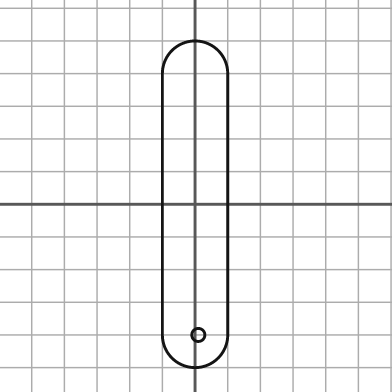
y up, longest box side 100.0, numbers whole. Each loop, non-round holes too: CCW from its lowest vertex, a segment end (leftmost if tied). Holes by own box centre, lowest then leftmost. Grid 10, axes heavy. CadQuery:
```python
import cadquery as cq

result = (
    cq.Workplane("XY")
    .moveTo(-10.0, -40.0)
    .threePointArc((0.0, -50.0), (10.0, -40.0))
    .lineTo(10.0, 40.0)
    .threePointArc((0.0, 50.0), (-10.0, 40.0))
    .close()
    .moveTo(1.0, -40.0)
    .circle(2.0)
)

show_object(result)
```